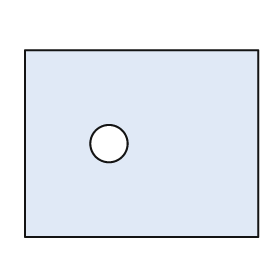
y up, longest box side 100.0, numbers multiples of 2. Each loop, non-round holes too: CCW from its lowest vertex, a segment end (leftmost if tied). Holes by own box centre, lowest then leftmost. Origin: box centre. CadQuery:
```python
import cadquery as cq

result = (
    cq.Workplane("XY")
    .moveTo(-50.0, -40.0)
    .lineTo(50.0, -40.0)
    .lineTo(50.0, 40.0)
    .lineTo(-50.0, 40.0)
    .close()
    .moveTo(-14.0, 0.0)
    .circle(8.0)
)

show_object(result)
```